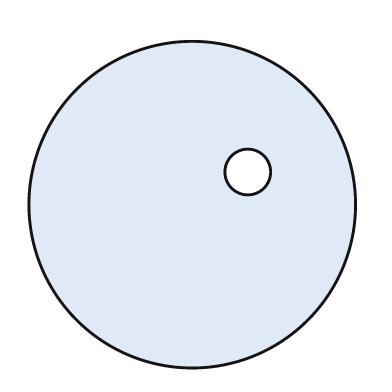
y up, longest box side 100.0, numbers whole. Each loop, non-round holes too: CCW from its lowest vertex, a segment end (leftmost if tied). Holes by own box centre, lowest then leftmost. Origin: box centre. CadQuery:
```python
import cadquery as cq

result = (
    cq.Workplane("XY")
    .moveTo(0.0, 0.0)
    .circle(50.0)
    .moveTo(17.0, 10.0)
    .circle(7.0)
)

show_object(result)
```